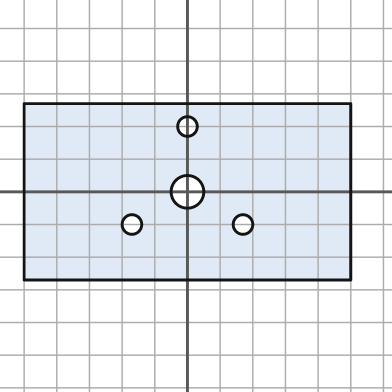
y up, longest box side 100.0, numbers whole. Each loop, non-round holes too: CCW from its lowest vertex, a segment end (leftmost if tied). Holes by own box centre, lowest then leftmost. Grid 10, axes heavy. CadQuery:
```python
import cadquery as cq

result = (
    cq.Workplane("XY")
    .moveTo(-50.0, -27.0)
    .lineTo(50.0, -27.0)
    .lineTo(50.0, 27.0)
    .lineTo(-50.0, 27.0)
    .close()
    .moveTo(-17.0, -10.0)
    .circle(3.0)
    .moveTo(17.0, -10.0)
    .circle(3.0)
    .moveTo(0.0, 0.0)
    .circle(5.0)
    .moveTo(0.0, 20.0)
    .circle(3.0)
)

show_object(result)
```